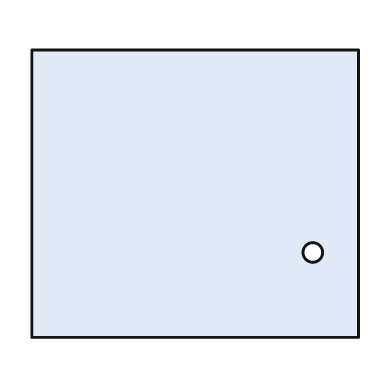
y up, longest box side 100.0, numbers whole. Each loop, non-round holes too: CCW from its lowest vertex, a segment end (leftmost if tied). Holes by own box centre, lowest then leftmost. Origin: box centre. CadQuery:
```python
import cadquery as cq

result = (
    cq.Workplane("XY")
    .moveTo(-50.0, -44.0)
    .lineTo(50.0, -44.0)
    .lineTo(50.0, 44.0)
    .lineTo(-50.0, 44.0)
    .close()
    .moveTo(36.0, -18.0)
    .circle(3.0)
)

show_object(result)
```